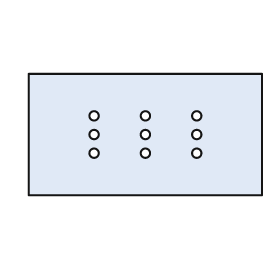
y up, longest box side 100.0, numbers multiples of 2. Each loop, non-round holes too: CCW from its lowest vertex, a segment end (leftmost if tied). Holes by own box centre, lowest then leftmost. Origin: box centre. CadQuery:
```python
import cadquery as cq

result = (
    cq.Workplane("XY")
    .moveTo(-50.0, -26.0)
    .lineTo(50.0, -26.0)
    .lineTo(50.0, 26.0)
    .lineTo(-50.0, 26.0)
    .close()
    .moveTo(-22.0, -8.0)
    .circle(2.0)
    .moveTo(0.0, -8.0)
    .circle(2.0)
    .moveTo(22.0, -8.0)
    .circle(2.0)
    .moveTo(-22.0, 0.0)
    .circle(2.0)
    .moveTo(0.0, 0.0)
    .circle(2.0)
    .moveTo(22.0, 0.0)
    .circle(2.0)
    .moveTo(-22.0, 8.0)
    .circle(2.0)
    .moveTo(0.0, 8.0)
    .circle(2.0)
    .moveTo(22.0, 8.0)
    .circle(2.0)
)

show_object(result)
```